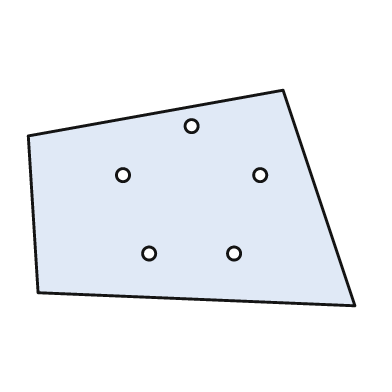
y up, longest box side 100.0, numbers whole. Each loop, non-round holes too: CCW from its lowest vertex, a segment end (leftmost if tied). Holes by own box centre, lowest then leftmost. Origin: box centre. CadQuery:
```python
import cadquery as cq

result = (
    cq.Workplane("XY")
    .moveTo(50.0, -33.0)
    .lineTo(28.0, 33.0)
    .lineTo(-50.0, 19.0)
    .lineTo(-47.0, -29.0)
    .close()
    .moveTo(-13.0, -17.0)
    .circle(2.0)
    .moveTo(13.0, -17.0)
    .circle(2.0)
    .moveTo(-21.0, 7.0)
    .circle(2.0)
    .moveTo(21.0, 7.0)
    .circle(2.0)
    .moveTo(0.0, 22.0)
    .circle(2.0)
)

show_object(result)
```